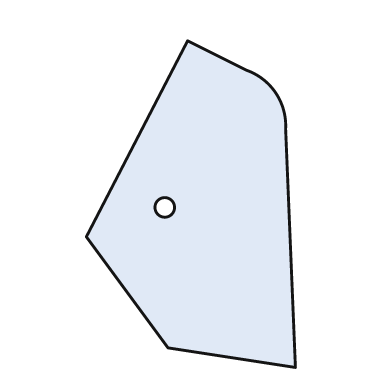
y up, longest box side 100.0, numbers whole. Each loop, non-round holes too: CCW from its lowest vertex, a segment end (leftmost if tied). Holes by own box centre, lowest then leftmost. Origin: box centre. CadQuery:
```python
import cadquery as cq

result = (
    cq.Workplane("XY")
    .moveTo(32.0, -50.0)
    .lineTo(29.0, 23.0)
    .threePointArc((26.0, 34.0), (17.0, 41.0))
    .lineTo(-1.0, 50.0)
    .lineTo(-32.0, -10.0)
    .lineTo(-7.0, -44.0)
    .close()
    .moveTo(-8.0, -1.0)
    .circle(3.0)
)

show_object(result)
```